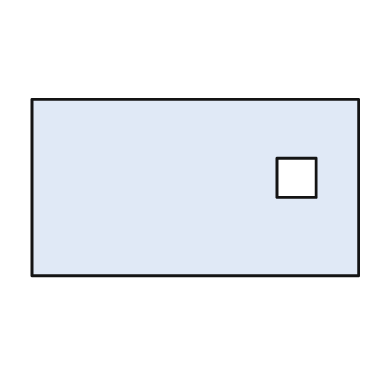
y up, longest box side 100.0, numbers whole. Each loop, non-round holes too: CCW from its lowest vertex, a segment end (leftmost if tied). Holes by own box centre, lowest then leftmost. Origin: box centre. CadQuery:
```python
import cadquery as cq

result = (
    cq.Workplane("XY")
    .moveTo(-50.0, -27.0)
    .lineTo(50.0, -27.0)
    .lineTo(50.0, 27.0)
    .lineTo(-50.0, 27.0)
    .close()
    .moveTo(25.0, -3.0)
    .lineTo(37.0, -3.0)
    .lineTo(37.0, 9.0)
    .lineTo(25.0, 9.0)
    .close()
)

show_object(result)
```